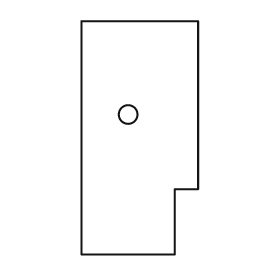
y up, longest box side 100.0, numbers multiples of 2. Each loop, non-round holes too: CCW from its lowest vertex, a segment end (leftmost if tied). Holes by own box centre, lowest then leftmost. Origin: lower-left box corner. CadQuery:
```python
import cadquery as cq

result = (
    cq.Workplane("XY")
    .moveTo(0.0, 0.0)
    .lineTo(40.0, 0.0)
    .lineTo(40.0, 28.0)
    .lineTo(50.0, 28.0)
    .lineTo(50.0, 100.0)
    .lineTo(0.0, 100.0)
    .close()
    .moveTo(20.0, 60.0)
    .circle(4.0)
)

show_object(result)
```